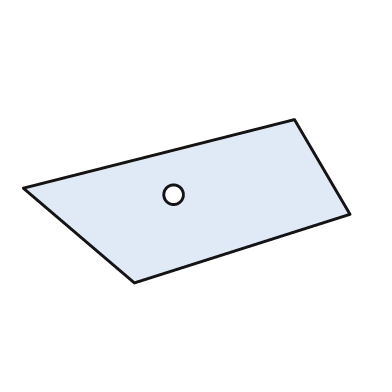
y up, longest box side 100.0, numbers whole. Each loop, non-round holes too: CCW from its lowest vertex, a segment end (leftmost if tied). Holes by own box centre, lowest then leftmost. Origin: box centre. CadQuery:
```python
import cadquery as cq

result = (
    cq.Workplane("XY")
    .moveTo(-16.0, -25.0)
    .lineTo(50.0, -4.0)
    .lineTo(33.0, 25.0)
    .lineTo(-50.0, 4.0)
    .close()
    .moveTo(-4.0, 2.0)
    .circle(3.0)
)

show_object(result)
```